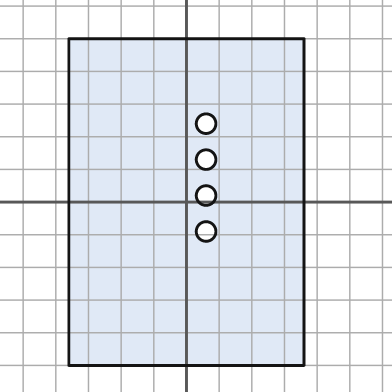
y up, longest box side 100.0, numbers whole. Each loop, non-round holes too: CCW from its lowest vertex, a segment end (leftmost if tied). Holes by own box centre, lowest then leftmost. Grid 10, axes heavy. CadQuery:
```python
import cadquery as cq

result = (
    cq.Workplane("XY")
    .moveTo(-36.0, -50.0)
    .lineTo(36.0, -50.0)
    .lineTo(36.0, 50.0)
    .lineTo(-36.0, 50.0)
    .close()
    .moveTo(6.0, -9.0)
    .circle(3.0)
    .moveTo(6.0, 2.0)
    .circle(3.0)
    .moveTo(6.0, 13.0)
    .circle(3.0)
    .moveTo(6.0, 24.0)
    .circle(3.0)
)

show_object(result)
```